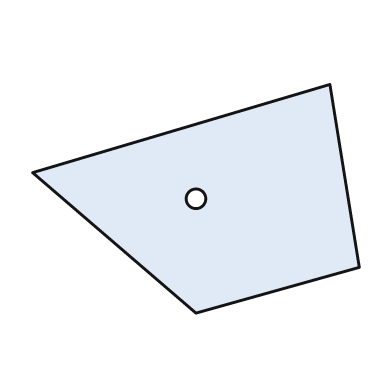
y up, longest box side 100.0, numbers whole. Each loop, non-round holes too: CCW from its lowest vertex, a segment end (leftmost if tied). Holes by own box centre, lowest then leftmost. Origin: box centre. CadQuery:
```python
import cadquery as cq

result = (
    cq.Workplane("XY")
    .moveTo(0.0, -35.0)
    .lineTo(50.0, -21.0)
    .lineTo(41.0, 35.0)
    .lineTo(-50.0, 8.0)
    .close()
    .moveTo(0.0, 0.0)
    .circle(3.0)
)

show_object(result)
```